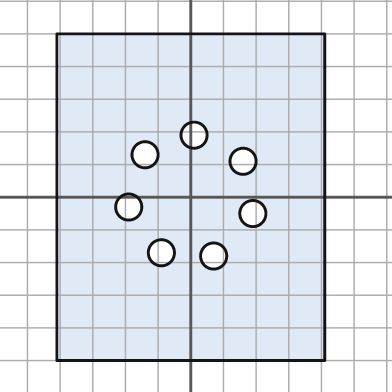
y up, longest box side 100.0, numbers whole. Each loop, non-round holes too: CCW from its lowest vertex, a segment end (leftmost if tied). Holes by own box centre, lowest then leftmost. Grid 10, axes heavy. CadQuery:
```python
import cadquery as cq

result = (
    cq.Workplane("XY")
    .moveTo(-41.0, -50.0)
    .lineTo(41.0, -50.0)
    .lineTo(41.0, 50.0)
    .lineTo(-41.0, 50.0)
    .close()
    .moveTo(7.0, -18.0)
    .circle(4.0)
    .moveTo(-9.0, -17.0)
    .circle(4.0)
    .moveTo(19.0, -5.0)
    .circle(4.0)
    .moveTo(-19.0, -3.0)
    .circle(4.0)
    .moveTo(16.0, 11.0)
    .circle(4.0)
    .moveTo(-14.0, 13.0)
    .circle(4.0)
    .moveTo(1.0, 19.0)
    .circle(4.0)
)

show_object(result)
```